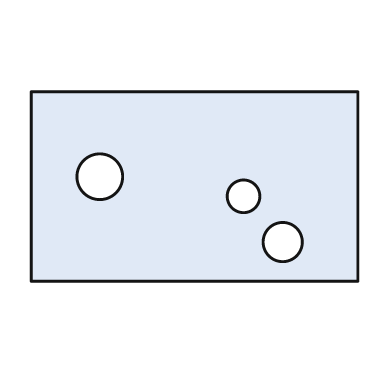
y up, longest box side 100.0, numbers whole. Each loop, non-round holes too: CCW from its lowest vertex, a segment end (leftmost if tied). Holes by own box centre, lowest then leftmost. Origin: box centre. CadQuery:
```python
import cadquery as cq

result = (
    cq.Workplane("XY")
    .moveTo(-50.0, -29.0)
    .lineTo(50.0, -29.0)
    .lineTo(50.0, 29.0)
    .lineTo(-50.0, 29.0)
    .close()
    .moveTo(27.0, -17.0)
    .circle(6.0)
    .moveTo(15.0, -3.0)
    .circle(5.0)
    .moveTo(-29.0, 3.0)
    .circle(7.0)
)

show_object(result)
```